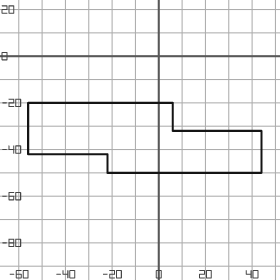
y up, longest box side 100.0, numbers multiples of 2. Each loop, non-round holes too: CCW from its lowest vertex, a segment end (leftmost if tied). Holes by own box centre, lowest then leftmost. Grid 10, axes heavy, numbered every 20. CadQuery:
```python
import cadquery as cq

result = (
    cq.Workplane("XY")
    .moveTo(-22.0, -50.0)
    .lineTo(44.0, -50.0)
    .lineTo(44.0, -32.0)
    .lineTo(6.0, -32.0)
    .lineTo(6.0, -20.0)
    .lineTo(-56.0, -20.0)
    .lineTo(-56.0, -42.0)
    .lineTo(-22.0, -42.0)
    .close()
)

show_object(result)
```